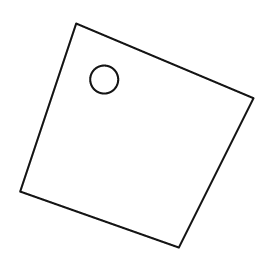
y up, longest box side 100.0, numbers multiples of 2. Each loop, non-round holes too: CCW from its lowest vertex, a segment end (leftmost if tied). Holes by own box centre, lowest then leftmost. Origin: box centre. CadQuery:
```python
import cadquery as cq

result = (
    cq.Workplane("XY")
    .moveTo(18.0, -48.0)
    .lineTo(50.0, 16.0)
    .lineTo(-26.0, 48.0)
    .lineTo(-50.0, -24.0)
    .close()
    .moveTo(-14.0, 24.0)
    .circle(6.0)
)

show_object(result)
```